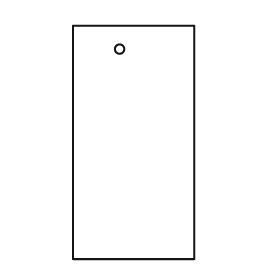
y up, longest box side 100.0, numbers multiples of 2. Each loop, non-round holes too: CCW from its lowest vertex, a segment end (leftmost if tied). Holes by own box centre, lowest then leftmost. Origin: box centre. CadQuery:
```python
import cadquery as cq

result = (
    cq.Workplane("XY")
    .moveTo(-26.0, -50.0)
    .lineTo(26.0, -50.0)
    .lineTo(26.0, 50.0)
    .lineTo(-26.0, 50.0)
    .close()
    .moveTo(-6.0, 40.0)
    .circle(2.0)
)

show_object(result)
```